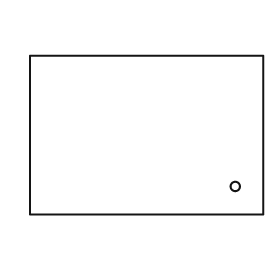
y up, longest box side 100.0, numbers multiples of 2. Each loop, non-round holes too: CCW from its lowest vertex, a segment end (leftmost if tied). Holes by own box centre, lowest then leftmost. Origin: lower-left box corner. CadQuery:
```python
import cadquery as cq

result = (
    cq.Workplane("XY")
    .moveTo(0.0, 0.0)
    .lineTo(100.0, 0.0)
    .lineTo(100.0, 68.0)
    .lineTo(0.0, 68.0)
    .close()
    .moveTo(88.0, 12.0)
    .circle(2.0)
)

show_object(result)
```